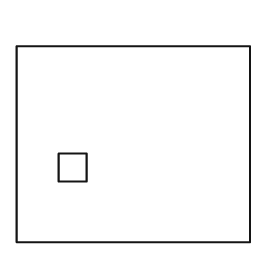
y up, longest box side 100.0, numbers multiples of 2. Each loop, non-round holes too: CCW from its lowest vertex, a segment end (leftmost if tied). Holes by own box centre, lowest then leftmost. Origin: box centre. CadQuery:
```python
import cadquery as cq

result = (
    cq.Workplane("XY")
    .moveTo(-50.0, -42.0)
    .lineTo(50.0, -42.0)
    .lineTo(50.0, 42.0)
    .lineTo(-50.0, 42.0)
    .close()
    .moveTo(-32.0, -16.0)
    .lineTo(-20.0, -16.0)
    .lineTo(-20.0, -4.0)
    .lineTo(-32.0, -4.0)
    .close()
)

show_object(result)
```